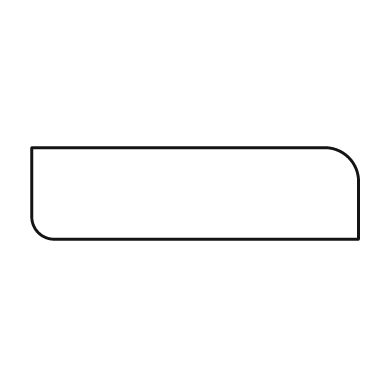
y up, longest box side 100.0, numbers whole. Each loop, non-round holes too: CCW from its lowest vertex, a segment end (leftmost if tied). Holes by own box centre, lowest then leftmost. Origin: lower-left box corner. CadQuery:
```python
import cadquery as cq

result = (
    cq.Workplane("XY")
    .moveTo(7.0, 0.0)
    .lineTo(100.0, 0.0)
    .lineTo(100.0, 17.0)
    .threePointArc((97.0, 25.0), (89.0, 28.0))
    .lineTo(0.0, 28.0)
    .lineTo(0.0, 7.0)
    .threePointArc((2.0, 2.0), (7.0, 0.0))
    .close()
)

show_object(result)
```